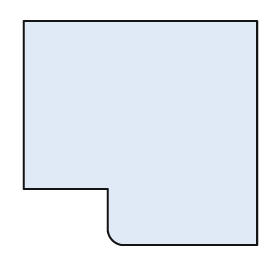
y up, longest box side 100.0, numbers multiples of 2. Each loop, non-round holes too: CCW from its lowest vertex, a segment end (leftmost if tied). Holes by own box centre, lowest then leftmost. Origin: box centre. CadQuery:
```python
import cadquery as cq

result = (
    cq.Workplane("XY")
    .moveTo(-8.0, -48.0)
    .lineTo(50.0, -48.0)
    .lineTo(50.0, 48.0)
    .lineTo(-50.0, 48.0)
    .lineTo(-50.0, -24.0)
    .lineTo(-14.0, -24.0)
    .lineTo(-14.0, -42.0)
    .threePointArc((-12.0, -46.0), (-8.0, -48.0))
    .close()
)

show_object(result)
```